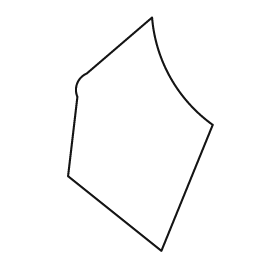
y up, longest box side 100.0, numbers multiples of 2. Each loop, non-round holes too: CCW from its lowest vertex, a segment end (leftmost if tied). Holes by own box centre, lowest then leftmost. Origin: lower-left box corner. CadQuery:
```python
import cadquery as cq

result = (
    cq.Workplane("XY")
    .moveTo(40.0, 0.0)
    .lineTo(62.0, 54.0)
    .threePointArc((44.0, 74.0), (36.0, 100.0))
    .lineTo(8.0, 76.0)
    .threePointArc((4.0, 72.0), (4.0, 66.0))
    .lineTo(0.0, 32.0)
    .close()
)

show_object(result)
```